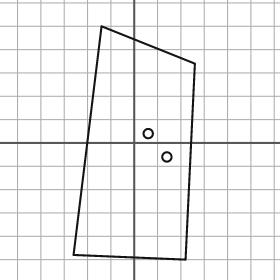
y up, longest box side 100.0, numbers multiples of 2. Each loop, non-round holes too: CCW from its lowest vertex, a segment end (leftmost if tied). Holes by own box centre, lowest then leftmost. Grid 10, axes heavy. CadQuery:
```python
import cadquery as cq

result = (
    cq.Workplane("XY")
    .moveTo(22.0, -50.0)
    .lineTo(26.0, 34.0)
    .lineTo(-14.0, 50.0)
    .lineTo(-26.0, -48.0)
    .close()
    .moveTo(14.0, -6.0)
    .circle(2.0)
    .moveTo(6.0, 4.0)
    .circle(2.0)
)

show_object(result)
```